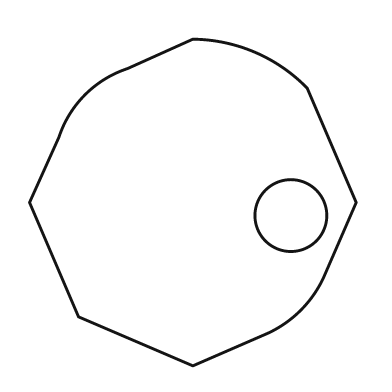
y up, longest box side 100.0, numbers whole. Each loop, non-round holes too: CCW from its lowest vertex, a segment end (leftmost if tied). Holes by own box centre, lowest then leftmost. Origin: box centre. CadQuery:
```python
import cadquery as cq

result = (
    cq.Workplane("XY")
    .moveTo(0.0, -50.0)
    .lineTo(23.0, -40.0)
    .threePointArc((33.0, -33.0), (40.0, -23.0))
    .lineTo(50.0, 0.0)
    .lineTo(35.0, 35.0)
    .threePointArc((19.0, 46.0), (0.0, 50.0))
    .lineTo(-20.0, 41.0)
    .threePointArc((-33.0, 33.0), (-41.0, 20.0))
    .lineTo(-50.0, 0.0)
    .lineTo(-35.0, -35.0)
    .close()
    .moveTo(30.0, -4.0)
    .circle(11.0)
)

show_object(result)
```